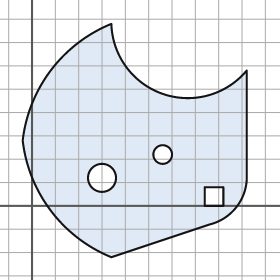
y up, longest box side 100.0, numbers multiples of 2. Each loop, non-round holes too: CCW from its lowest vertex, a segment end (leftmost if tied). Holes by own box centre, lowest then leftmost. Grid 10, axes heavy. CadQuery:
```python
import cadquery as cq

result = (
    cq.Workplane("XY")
    .moveTo(34.0, -22.0)
    .lineTo(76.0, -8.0)
    .threePointArc((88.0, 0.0), (92.0, 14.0))
    .lineTo(92.0, 58.0)
    .threePointArc((56.0, 48.0), (34.0, 78.0))
    .threePointArc((8.0, 58.0), (-4.0, 28.0))
    .threePointArc((8.0, -2.0), (34.0, -22.0))
    .close()
    .moveTo(74.0, 0.0)
    .lineTo(82.0, 0.0)
    .lineTo(82.0, 8.0)
    .lineTo(74.0, 8.0)
    .close()
    .moveTo(30.0, 12.0)
    .circle(6.0)
    .moveTo(56.0, 22.0)
    .circle(4.0)
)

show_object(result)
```